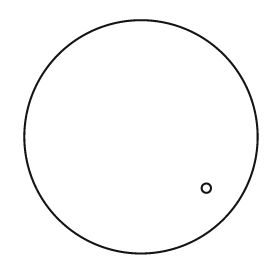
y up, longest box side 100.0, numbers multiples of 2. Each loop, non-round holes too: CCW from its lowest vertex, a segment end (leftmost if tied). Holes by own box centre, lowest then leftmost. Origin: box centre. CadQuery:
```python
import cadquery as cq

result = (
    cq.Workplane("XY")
    .moveTo(0.0, 0.0)
    .circle(50.0)
    .moveTo(28.0, -22.0)
    .circle(2.0)
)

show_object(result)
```